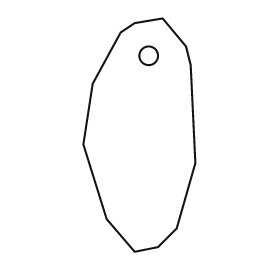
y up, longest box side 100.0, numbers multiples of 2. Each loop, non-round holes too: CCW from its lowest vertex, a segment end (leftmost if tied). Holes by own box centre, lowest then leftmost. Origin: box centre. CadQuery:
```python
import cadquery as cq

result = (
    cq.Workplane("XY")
    .moveTo(-2.0, -50.0)
    .lineTo(8.0, -48.0)
    .lineTo(16.0, -40.0)
    .lineTo(24.0, -12.0)
    .lineTo(22.0, 30.0)
    .lineTo(20.0, 38.0)
    .lineTo(10.0, 50.0)
    .lineTo(-2.0, 48.0)
    .lineTo(-8.0, 44.0)
    .lineTo(-20.0, 22.0)
    .lineTo(-24.0, -4.0)
    .lineTo(-14.0, -36.0)
    .close()
    .moveTo(4.0, 34.0)
    .circle(4.0)
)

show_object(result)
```